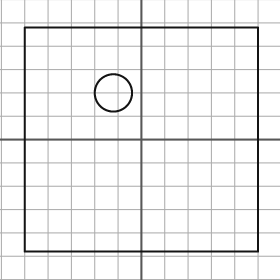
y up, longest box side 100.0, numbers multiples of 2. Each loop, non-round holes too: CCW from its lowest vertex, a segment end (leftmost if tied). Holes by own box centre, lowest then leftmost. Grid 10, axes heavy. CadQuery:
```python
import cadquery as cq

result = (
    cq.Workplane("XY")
    .moveTo(-50.0, -48.0)
    .lineTo(50.0, -48.0)
    .lineTo(50.0, 48.0)
    .lineTo(-50.0, 48.0)
    .close()
    .moveTo(-12.0, 20.0)
    .circle(8.0)
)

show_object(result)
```